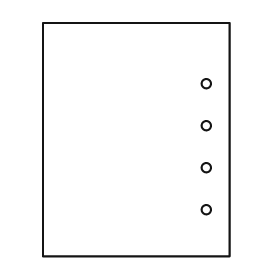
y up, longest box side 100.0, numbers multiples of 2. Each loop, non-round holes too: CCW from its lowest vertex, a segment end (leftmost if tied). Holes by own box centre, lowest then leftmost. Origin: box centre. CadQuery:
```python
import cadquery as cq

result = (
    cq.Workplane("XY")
    .moveTo(-40.0, -50.0)
    .lineTo(40.0, -50.0)
    .lineTo(40.0, 50.0)
    .lineTo(-40.0, 50.0)
    .close()
    .moveTo(30.0, -30.0)
    .circle(2.0)
    .moveTo(30.0, -12.0)
    .circle(2.0)
    .moveTo(30.0, 6.0)
    .circle(2.0)
    .moveTo(30.0, 24.0)
    .circle(2.0)
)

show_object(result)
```